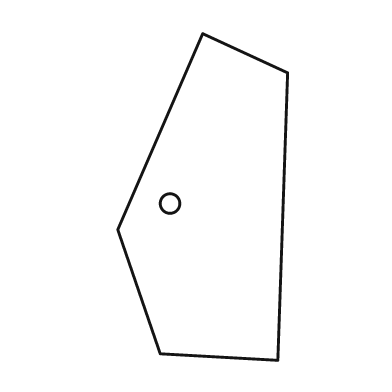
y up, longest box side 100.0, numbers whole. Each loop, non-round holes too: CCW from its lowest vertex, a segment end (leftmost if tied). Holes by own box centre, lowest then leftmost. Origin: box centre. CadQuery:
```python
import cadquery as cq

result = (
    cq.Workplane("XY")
    .moveTo(23.0, -50.0)
    .lineTo(26.0, 38.0)
    .lineTo(0.0, 50.0)
    .lineTo(-26.0, -10.0)
    .lineTo(-13.0, -48.0)
    .close()
    .moveTo(-10.0, -2.0)
    .circle(3.0)
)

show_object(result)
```